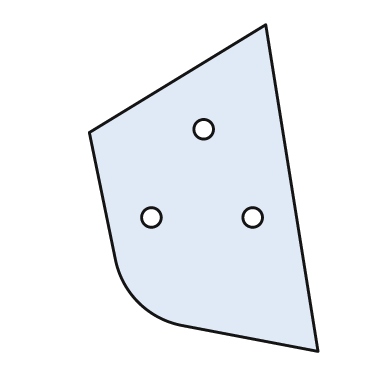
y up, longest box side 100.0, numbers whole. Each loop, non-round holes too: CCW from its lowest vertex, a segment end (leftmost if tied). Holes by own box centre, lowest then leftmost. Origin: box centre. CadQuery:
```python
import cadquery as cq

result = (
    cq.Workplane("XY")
    .moveTo(35.0, -50.0)
    .lineTo(19.0, 50.0)
    .lineTo(-35.0, 17.0)
    .lineTo(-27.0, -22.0)
    .threePointArc((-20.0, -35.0), (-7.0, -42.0))
    .close()
    .moveTo(-16.0, -9.0)
    .circle(3.0)
    .moveTo(15.0, -9.0)
    .circle(3.0)
    .moveTo(0.0, 18.0)
    .circle(3.0)
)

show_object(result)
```